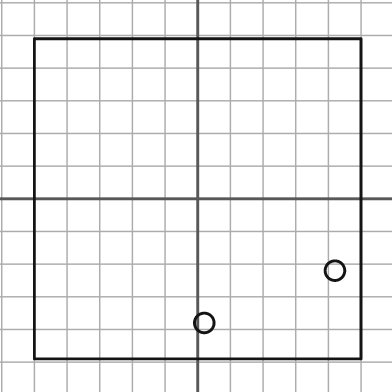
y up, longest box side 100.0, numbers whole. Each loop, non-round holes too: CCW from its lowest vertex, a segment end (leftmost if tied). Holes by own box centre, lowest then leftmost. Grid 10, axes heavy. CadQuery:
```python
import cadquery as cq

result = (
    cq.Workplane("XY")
    .moveTo(-50.0, -49.0)
    .lineTo(50.0, -49.0)
    .lineTo(50.0, 49.0)
    .lineTo(-50.0, 49.0)
    .close()
    .moveTo(2.0, -38.0)
    .circle(3.0)
    .moveTo(42.0, -22.0)
    .circle(3.0)
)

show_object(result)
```